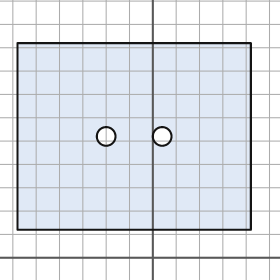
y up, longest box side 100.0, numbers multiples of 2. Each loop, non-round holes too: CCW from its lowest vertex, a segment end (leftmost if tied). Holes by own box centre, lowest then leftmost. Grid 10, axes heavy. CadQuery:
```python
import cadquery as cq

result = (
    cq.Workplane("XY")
    .moveTo(-58.0, 12.0)
    .lineTo(42.0, 12.0)
    .lineTo(42.0, 92.0)
    .lineTo(-58.0, 92.0)
    .close()
    .moveTo(-20.0, 52.0)
    .circle(4.0)
    .moveTo(4.0, 52.0)
    .circle(4.0)
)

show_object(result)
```